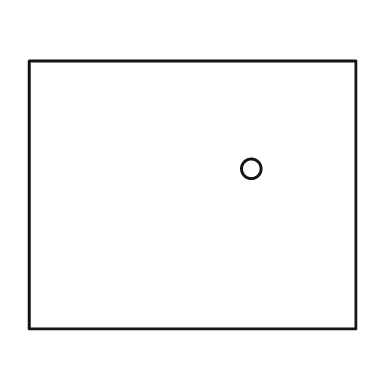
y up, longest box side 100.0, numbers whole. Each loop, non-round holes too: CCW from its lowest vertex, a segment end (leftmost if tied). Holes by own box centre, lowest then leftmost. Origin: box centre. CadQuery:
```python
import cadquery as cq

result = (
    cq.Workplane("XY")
    .moveTo(-50.0, -41.0)
    .lineTo(50.0, -41.0)
    .lineTo(50.0, 41.0)
    .lineTo(-50.0, 41.0)
    .close()
    .moveTo(18.0, 8.0)
    .circle(3.0)
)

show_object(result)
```